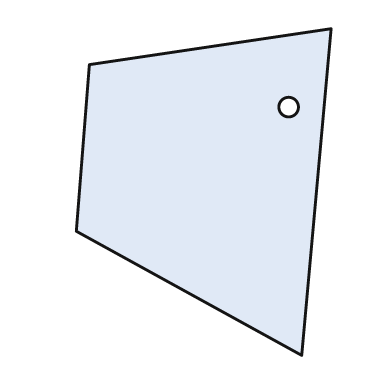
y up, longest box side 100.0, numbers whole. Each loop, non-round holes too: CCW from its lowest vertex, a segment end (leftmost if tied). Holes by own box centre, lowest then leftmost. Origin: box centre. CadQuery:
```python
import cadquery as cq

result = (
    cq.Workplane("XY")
    .moveTo(30.0, -50.0)
    .lineTo(39.0, 50.0)
    .lineTo(-35.0, 39.0)
    .lineTo(-39.0, -12.0)
    .close()
    .moveTo(26.0, 26.0)
    .circle(3.0)
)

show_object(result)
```